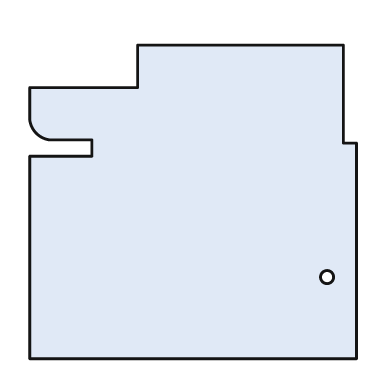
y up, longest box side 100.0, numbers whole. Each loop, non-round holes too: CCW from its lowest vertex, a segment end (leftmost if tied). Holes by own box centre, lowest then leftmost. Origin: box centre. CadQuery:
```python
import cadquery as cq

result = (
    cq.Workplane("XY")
    .moveTo(-50.0, -48.0)
    .lineTo(50.0, -48.0)
    .lineTo(50.0, 18.0)
    .lineTo(46.0, 18.0)
    .lineTo(46.0, 48.0)
    .lineTo(-17.0, 48.0)
    .lineTo(-17.0, 35.0)
    .lineTo(-50.0, 35.0)
    .lineTo(-50.0, 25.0)
    .threePointArc((-48.0, 21.0), (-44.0, 19.0))
    .lineTo(-31.0, 19.0)
    .lineTo(-31.0, 14.0)
    .lineTo(-50.0, 14.0)
    .close()
    .moveTo(41.0, -23.0)
    .circle(2.0)
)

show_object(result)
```